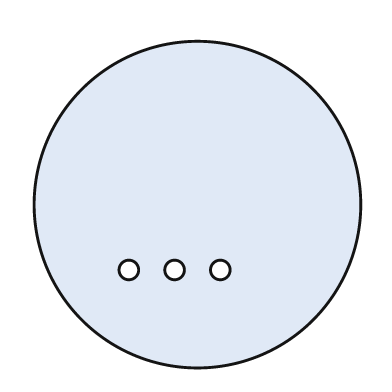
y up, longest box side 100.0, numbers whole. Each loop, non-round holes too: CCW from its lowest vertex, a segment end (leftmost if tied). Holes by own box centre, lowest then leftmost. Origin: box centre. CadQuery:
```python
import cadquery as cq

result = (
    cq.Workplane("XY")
    .moveTo(0.0, 0.0)
    .circle(50.0)
    .moveTo(-21.0, -20.0)
    .circle(3.0)
    .moveTo(-7.0, -20.0)
    .circle(3.0)
    .moveTo(7.0, -20.0)
    .circle(3.0)
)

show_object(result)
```